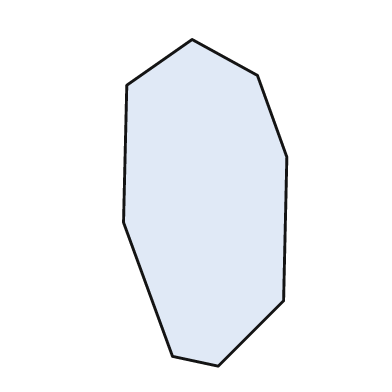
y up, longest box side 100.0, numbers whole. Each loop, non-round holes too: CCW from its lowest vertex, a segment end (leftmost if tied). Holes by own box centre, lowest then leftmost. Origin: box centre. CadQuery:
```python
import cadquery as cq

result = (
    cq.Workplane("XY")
    .moveTo(4.0, -50.0)
    .lineTo(24.0, -30.0)
    .lineTo(25.0, 14.0)
    .lineTo(16.0, 39.0)
    .lineTo(-4.0, 50.0)
    .lineTo(-24.0, 36.0)
    .lineTo(-25.0, -6.0)
    .lineTo(-10.0, -47.0)
    .close()
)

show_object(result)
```